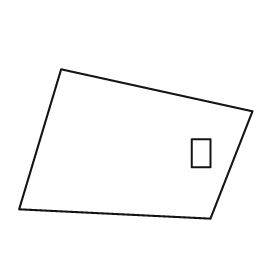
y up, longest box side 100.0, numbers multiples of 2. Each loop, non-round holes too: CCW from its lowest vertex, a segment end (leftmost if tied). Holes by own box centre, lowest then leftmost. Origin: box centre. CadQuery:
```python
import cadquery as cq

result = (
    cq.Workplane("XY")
    .moveTo(32.0, -32.0)
    .lineTo(50.0, 14.0)
    .lineTo(-32.0, 32.0)
    .lineTo(-50.0, -28.0)
    .close()
    .moveTo(24.0, -10.0)
    .lineTo(32.0, -10.0)
    .lineTo(32.0, 2.0)
    .lineTo(24.0, 2.0)
    .close()
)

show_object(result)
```